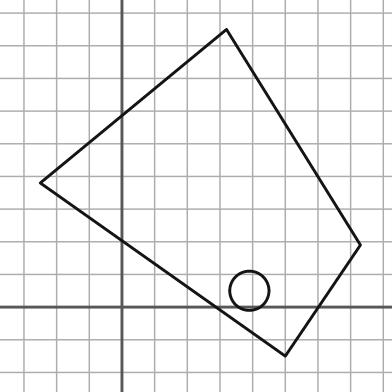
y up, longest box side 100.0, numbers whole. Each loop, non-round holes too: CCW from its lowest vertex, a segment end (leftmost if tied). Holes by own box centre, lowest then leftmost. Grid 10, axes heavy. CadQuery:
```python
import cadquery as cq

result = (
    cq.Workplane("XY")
    .moveTo(50.0, -15.0)
    .lineTo(73.0, 19.0)
    .lineTo(32.0, 85.0)
    .lineTo(-25.0, 38.0)
    .close()
    .moveTo(39.0, 5.0)
    .circle(6.0)
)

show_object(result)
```